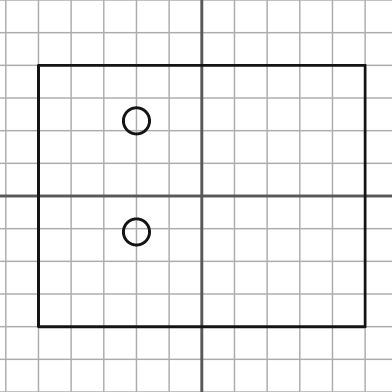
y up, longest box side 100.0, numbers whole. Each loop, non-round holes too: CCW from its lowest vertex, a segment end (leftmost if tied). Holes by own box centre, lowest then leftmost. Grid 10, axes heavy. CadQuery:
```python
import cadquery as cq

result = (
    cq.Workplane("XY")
    .moveTo(-50.0, -40.0)
    .lineTo(50.0, -40.0)
    .lineTo(50.0, 40.0)
    .lineTo(-50.0, 40.0)
    .close()
    .moveTo(-20.0, -11.0)
    .circle(4.0)
    .moveTo(-20.0, 23.0)
    .circle(4.0)
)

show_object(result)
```